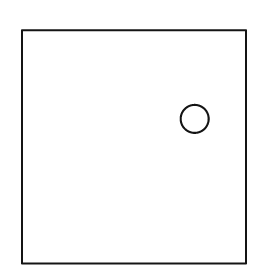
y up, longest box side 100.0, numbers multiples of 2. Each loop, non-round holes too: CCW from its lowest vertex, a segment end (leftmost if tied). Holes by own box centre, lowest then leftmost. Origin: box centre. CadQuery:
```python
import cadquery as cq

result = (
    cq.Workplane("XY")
    .moveTo(-48.0, -50.0)
    .lineTo(48.0, -50.0)
    .lineTo(48.0, 50.0)
    .lineTo(-48.0, 50.0)
    .close()
    .moveTo(26.0, 12.0)
    .circle(6.0)
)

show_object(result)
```